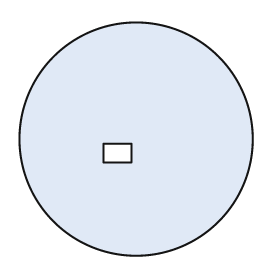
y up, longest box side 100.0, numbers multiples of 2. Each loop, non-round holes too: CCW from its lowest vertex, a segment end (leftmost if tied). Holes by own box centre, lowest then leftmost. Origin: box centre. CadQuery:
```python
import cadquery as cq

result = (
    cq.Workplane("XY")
    .moveTo(0.0, 0.0)
    .circle(50.0)
    .moveTo(-14.0, -10.0)
    .lineTo(-2.0, -10.0)
    .lineTo(-2.0, -2.0)
    .lineTo(-14.0, -2.0)
    .close()
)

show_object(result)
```